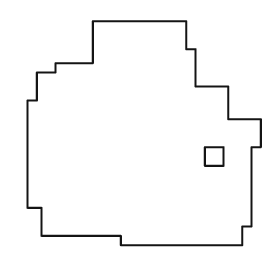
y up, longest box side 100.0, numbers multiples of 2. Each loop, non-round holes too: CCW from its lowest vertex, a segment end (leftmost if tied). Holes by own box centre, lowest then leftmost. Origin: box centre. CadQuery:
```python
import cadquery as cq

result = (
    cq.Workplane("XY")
    .moveTo(-10.0, -48.0)
    .lineTo(42.0, -48.0)
    .lineTo(42.0, -40.0)
    .lineTo(46.0, -40.0)
    .lineTo(46.0, -6.0)
    .lineTo(50.0, -6.0)
    .lineTo(50.0, 6.0)
    .lineTo(36.0, 6.0)
    .lineTo(36.0, 20.0)
    .lineTo(22.0, 20.0)
    .lineTo(22.0, 36.0)
    .lineTo(18.0, 36.0)
    .lineTo(18.0, 48.0)
    .lineTo(-22.0, 48.0)
    .lineTo(-22.0, 30.0)
    .lineTo(-38.0, 30.0)
    .lineTo(-38.0, 26.0)
    .lineTo(-46.0, 26.0)
    .lineTo(-46.0, 14.0)
    .lineTo(-50.0, 14.0)
    .lineTo(-50.0, -32.0)
    .lineTo(-44.0, -32.0)
    .lineTo(-44.0, -44.0)
    .lineTo(-10.0, -44.0)
    .close()
    .moveTo(26.0, -14.0)
    .lineTo(34.0, -14.0)
    .lineTo(34.0, -6.0)
    .lineTo(26.0, -6.0)
    .close()
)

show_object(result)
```